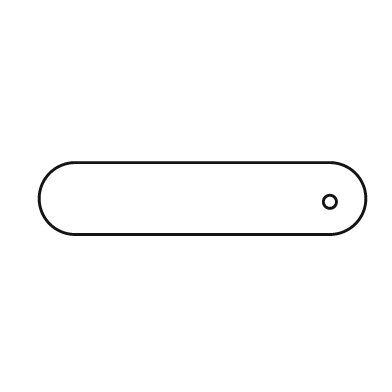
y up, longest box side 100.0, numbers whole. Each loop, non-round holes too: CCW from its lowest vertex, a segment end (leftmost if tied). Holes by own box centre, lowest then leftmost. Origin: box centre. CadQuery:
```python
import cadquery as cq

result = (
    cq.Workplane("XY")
    .moveTo(-39.0, -11.0)
    .lineTo(39.0, -11.0)
    .threePointArc((50.0, 0.0), (39.0, 11.0))
    .lineTo(-39.0, 11.0)
    .threePointArc((-50.0, 0.0), (-39.0, -11.0))
    .close()
    .moveTo(39.0, -1.0)
    .circle(2.0)
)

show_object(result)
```